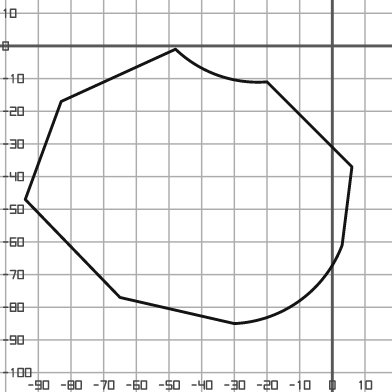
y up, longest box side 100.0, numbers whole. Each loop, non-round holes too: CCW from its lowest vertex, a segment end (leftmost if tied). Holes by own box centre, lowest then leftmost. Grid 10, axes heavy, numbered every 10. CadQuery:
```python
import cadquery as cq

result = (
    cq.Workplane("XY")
    .moveTo(-30.0, -85.0)
    .threePointArc((-10.0, -78.0), (3.0, -61.0))
    .lineTo(6.0, -37.0)
    .lineTo(-20.0, -11.0)
    .threePointArc((-35.0, -9.0), (-48.0, -1.0))
    .lineTo(-83.0, -17.0)
    .lineTo(-94.0, -47.0)
    .lineTo(-65.0, -77.0)
    .close()
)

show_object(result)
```